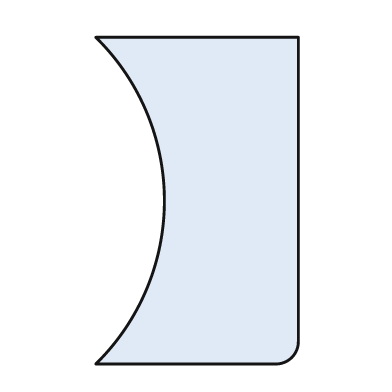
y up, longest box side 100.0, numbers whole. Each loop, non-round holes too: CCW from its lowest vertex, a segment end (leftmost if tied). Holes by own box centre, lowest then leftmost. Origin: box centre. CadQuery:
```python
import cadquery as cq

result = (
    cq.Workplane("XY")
    .moveTo(-31.0, -50.0)
    .lineTo(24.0, -50.0)
    .threePointArc((29.0, -48.0), (31.0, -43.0))
    .lineTo(31.0, 50.0)
    .lineTo(-31.0, 50.0)
    .threePointArc((-10.0, 0.0), (-31.0, -50.0))
    .close()
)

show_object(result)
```